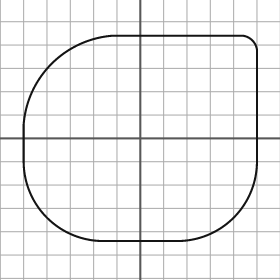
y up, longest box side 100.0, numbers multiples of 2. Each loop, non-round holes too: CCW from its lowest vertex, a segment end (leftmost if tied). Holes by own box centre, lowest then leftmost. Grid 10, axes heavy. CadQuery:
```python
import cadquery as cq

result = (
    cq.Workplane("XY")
    .moveTo(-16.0, -44.0)
    .lineTo(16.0, -44.0)
    .threePointArc((40.0, -34.0), (50.0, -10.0))
    .lineTo(50.0, 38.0)
    .threePointArc((48.0, 42.0), (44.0, 44.0))
    .lineTo(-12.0, 44.0)
    .threePointArc((-38.0, 32.0), (-50.0, 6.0))
    .lineTo(-50.0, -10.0)
    .threePointArc((-40.0, -34.0), (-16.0, -44.0))
    .close()
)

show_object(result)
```